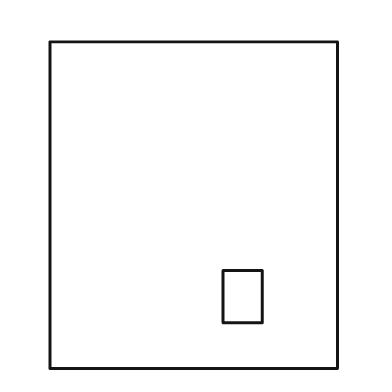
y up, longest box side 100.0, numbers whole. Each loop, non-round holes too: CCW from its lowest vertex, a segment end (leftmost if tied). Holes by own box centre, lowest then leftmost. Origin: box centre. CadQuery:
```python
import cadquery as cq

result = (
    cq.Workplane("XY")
    .moveTo(-44.0, -50.0)
    .lineTo(44.0, -50.0)
    .lineTo(44.0, 50.0)
    .lineTo(-44.0, 50.0)
    .close()
    .moveTo(9.0, -36.0)
    .lineTo(21.0, -36.0)
    .lineTo(21.0, -20.0)
    .lineTo(9.0, -20.0)
    .close()
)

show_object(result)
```